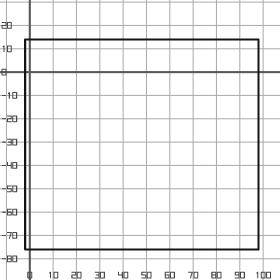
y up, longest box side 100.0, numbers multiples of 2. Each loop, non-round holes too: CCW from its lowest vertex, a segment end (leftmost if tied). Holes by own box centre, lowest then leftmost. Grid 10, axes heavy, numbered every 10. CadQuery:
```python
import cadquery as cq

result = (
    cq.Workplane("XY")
    .moveTo(-2.0, -76.0)
    .lineTo(98.0, -76.0)
    .lineTo(98.0, 14.0)
    .lineTo(-2.0, 14.0)
    .close()
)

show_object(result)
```